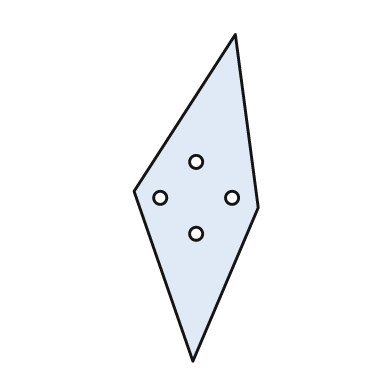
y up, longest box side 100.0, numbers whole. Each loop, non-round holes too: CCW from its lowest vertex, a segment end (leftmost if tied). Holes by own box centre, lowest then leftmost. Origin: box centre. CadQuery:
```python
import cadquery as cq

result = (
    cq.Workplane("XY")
    .moveTo(-1.0, -50.0)
    .lineTo(19.0, -3.0)
    .lineTo(12.0, 50.0)
    .lineTo(-19.0, 2.0)
    .close()
    .moveTo(0.0, -11.0)
    .circle(2.0)
    .moveTo(-11.0, 0.0)
    .circle(2.0)
    .moveTo(11.0, 0.0)
    .circle(2.0)
    .moveTo(0.0, 11.0)
    .circle(2.0)
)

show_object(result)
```